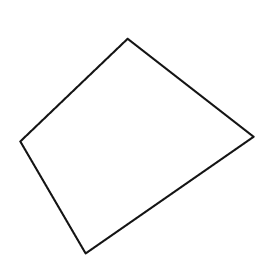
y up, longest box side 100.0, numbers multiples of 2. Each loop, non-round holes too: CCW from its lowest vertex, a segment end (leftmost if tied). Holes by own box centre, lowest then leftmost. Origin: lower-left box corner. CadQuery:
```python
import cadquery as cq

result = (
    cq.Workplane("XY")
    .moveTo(28.0, 0.0)
    .lineTo(100.0, 50.0)
    .lineTo(46.0, 92.0)
    .lineTo(0.0, 48.0)
    .close()
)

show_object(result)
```